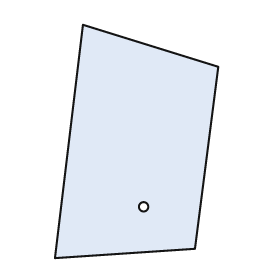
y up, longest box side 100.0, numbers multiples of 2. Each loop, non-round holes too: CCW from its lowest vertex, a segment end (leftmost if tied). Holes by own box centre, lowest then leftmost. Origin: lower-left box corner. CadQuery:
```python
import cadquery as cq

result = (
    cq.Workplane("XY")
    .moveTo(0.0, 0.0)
    .lineTo(60.0, 4.0)
    .lineTo(70.0, 82.0)
    .lineTo(12.0, 100.0)
    .close()
    .moveTo(38.0, 22.0)
    .circle(2.0)
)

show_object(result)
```